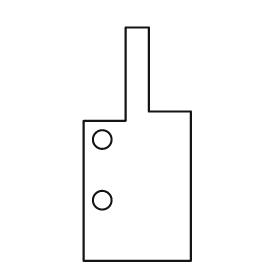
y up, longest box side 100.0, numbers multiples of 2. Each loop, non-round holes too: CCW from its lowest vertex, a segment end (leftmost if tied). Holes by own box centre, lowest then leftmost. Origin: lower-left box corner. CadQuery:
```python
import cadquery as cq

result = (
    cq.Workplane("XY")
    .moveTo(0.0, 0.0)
    .lineTo(46.0, 0.0)
    .lineTo(46.0, 64.0)
    .lineTo(28.0, 64.0)
    .lineTo(28.0, 100.0)
    .lineTo(18.0, 100.0)
    .lineTo(18.0, 60.0)
    .lineTo(0.0, 60.0)
    .close()
    .moveTo(8.0, 26.0)
    .circle(4.0)
    .moveTo(8.0, 52.0)
    .circle(4.0)
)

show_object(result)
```